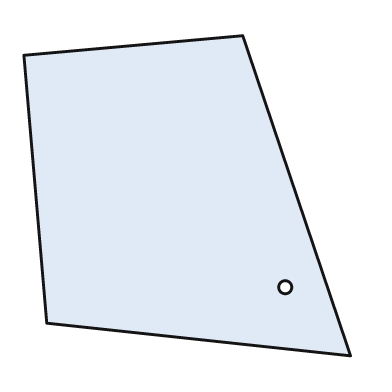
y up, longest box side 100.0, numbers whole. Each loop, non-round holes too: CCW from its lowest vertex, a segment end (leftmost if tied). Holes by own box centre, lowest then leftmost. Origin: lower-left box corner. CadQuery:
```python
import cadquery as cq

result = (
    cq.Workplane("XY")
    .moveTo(100.0, 0.0)
    .lineTo(67.0, 98.0)
    .lineTo(0.0, 92.0)
    .lineTo(7.0, 10.0)
    .close()
    .moveTo(80.0, 21.0)
    .circle(2.0)
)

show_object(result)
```